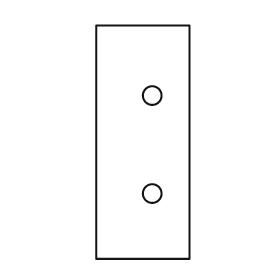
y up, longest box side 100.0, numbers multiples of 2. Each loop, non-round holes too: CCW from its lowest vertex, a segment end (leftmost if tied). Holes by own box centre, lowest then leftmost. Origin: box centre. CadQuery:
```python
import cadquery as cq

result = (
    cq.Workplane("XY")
    .moveTo(-20.0, -50.0)
    .lineTo(20.0, -50.0)
    .lineTo(20.0, 50.0)
    .lineTo(-20.0, 50.0)
    .close()
    .moveTo(4.0, -22.0)
    .circle(4.0)
    .moveTo(4.0, 20.0)
    .circle(4.0)
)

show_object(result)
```